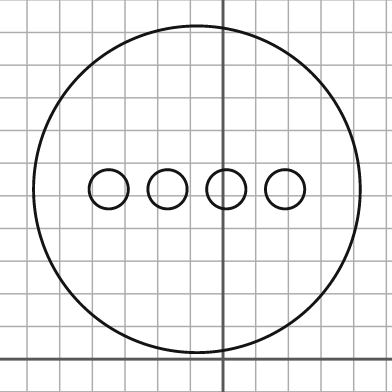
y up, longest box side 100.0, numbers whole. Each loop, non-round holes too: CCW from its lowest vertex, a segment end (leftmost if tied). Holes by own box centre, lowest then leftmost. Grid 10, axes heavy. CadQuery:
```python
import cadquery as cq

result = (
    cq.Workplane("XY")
    .moveTo(-8.0, 52.0)
    .circle(50.0)
    .moveTo(-35.0, 52.0)
    .circle(6.0)
    .moveTo(-17.0, 52.0)
    .circle(6.0)
    .moveTo(1.0, 52.0)
    .circle(6.0)
    .moveTo(19.0, 52.0)
    .circle(6.0)
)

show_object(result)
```